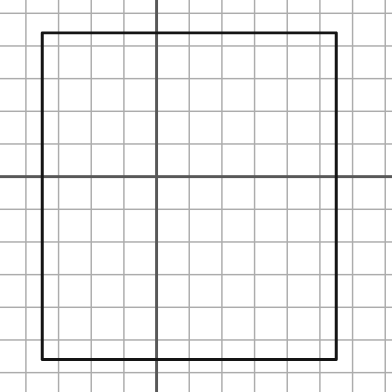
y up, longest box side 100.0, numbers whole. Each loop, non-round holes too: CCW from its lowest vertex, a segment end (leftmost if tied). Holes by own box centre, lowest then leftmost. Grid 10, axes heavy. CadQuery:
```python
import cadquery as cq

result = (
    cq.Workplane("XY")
    .moveTo(-35.0, -56.0)
    .lineTo(55.0, -56.0)
    .lineTo(55.0, 44.0)
    .lineTo(-35.0, 44.0)
    .close()
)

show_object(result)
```